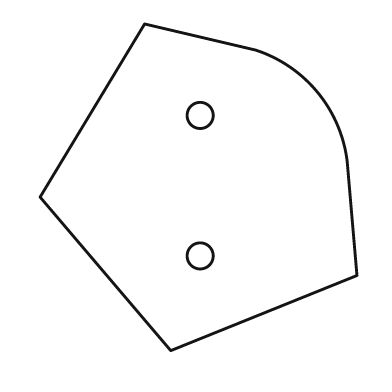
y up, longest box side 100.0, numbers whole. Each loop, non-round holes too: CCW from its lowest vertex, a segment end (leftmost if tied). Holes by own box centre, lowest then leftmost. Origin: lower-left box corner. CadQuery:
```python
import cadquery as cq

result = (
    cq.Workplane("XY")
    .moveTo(40.0, 0.0)
    .lineTo(97.0, 23.0)
    .lineTo(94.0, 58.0)
    .threePointArc((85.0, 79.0), (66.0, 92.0))
    .lineTo(32.0, 100.0)
    .lineTo(0.0, 47.0)
    .close()
    .moveTo(49.0, 29.0)
    .circle(4.0)
    .moveTo(49.0, 72.0)
    .circle(4.0)
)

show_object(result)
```